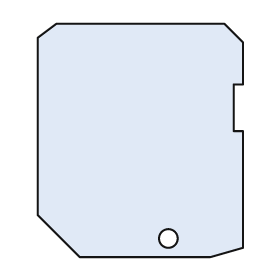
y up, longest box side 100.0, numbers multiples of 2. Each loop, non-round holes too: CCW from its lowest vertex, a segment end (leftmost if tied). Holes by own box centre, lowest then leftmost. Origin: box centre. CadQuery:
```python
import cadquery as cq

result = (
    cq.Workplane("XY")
    .moveTo(-26.0, -50.0)
    .lineTo(30.0, -50.0)
    .lineTo(44.0, -46.0)
    .lineTo(44.0, 4.0)
    .lineTo(40.0, 4.0)
    .lineTo(40.0, 24.0)
    .lineTo(44.0, 24.0)
    .lineTo(44.0, 42.0)
    .lineTo(36.0, 50.0)
    .lineTo(-36.0, 50.0)
    .lineTo(-44.0, 44.0)
    .lineTo(-44.0, -32.0)
    .close()
    .moveTo(12.0, -42.0)
    .circle(4.0)
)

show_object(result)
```